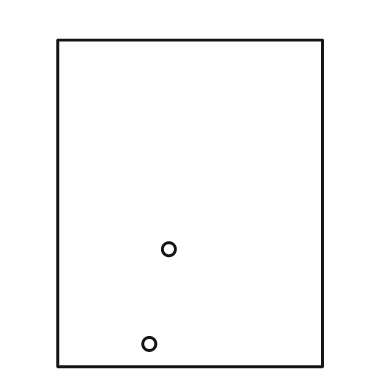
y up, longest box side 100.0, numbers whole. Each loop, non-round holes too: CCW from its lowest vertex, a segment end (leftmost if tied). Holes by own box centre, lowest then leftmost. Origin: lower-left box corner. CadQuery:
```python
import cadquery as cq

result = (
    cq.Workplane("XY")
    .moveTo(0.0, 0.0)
    .lineTo(81.0, 0.0)
    .lineTo(81.0, 100.0)
    .lineTo(0.0, 100.0)
    .close()
    .moveTo(28.0, 7.0)
    .circle(2.0)
    .moveTo(34.0, 36.0)
    .circle(2.0)
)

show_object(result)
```